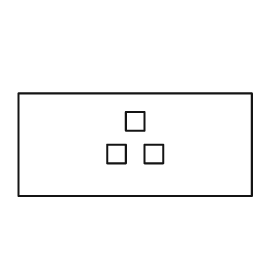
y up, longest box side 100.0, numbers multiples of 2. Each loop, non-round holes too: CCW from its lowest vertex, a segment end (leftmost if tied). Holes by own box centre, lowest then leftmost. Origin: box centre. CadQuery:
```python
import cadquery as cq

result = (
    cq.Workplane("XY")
    .moveTo(-50.0, -22.0)
    .lineTo(50.0, -22.0)
    .lineTo(50.0, 22.0)
    .lineTo(-50.0, 22.0)
    .close()
    .moveTo(-12.0, -8.0)
    .lineTo(-4.0, -8.0)
    .lineTo(-4.0, 0.0)
    .lineTo(-12.0, 0.0)
    .close()
    .moveTo(4.0, -8.0)
    .lineTo(12.0, -8.0)
    .lineTo(12.0, 0.0)
    .lineTo(4.0, 0.0)
    .close()
    .moveTo(-4.0, 6.0)
    .lineTo(4.0, 6.0)
    .lineTo(4.0, 14.0)
    .lineTo(-4.0, 14.0)
    .close()
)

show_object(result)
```